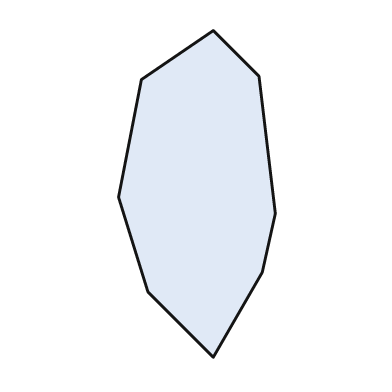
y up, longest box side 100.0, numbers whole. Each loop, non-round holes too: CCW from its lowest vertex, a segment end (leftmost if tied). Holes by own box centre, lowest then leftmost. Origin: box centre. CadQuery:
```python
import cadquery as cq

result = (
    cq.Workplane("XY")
    .moveTo(5.0, -50.0)
    .lineTo(20.0, -24.0)
    .lineTo(24.0, -6.0)
    .lineTo(19.0, 36.0)
    .lineTo(5.0, 50.0)
    .lineTo(-17.0, 35.0)
    .lineTo(-24.0, -1.0)
    .lineTo(-15.0, -30.0)
    .close()
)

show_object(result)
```